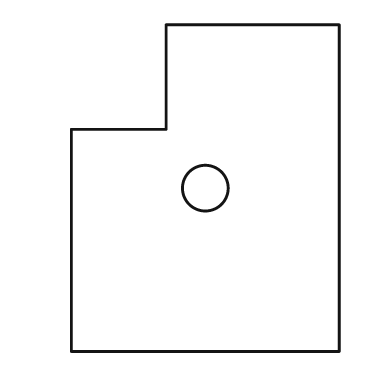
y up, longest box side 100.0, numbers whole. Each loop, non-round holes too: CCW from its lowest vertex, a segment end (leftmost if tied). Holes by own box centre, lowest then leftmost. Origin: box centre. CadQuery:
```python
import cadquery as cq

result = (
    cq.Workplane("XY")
    .moveTo(-41.0, -50.0)
    .lineTo(41.0, -50.0)
    .lineTo(41.0, 50.0)
    .lineTo(-12.0, 50.0)
    .lineTo(-12.0, 18.0)
    .lineTo(-41.0, 18.0)
    .close()
    .moveTo(0.0, 0.0)
    .circle(7.0)
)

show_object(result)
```